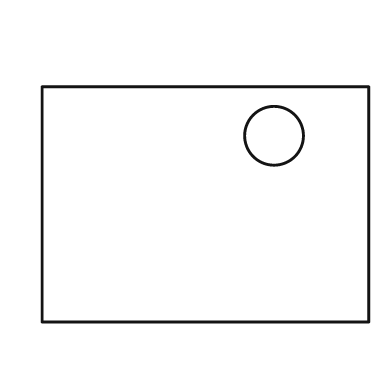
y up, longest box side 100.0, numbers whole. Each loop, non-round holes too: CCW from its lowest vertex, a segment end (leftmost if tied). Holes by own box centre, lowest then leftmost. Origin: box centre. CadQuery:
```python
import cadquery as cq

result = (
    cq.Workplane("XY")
    .moveTo(-50.0, -36.0)
    .lineTo(50.0, -36.0)
    .lineTo(50.0, 36.0)
    .lineTo(-50.0, 36.0)
    .close()
    .moveTo(21.0, 21.0)
    .circle(9.0)
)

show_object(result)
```